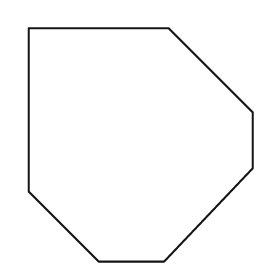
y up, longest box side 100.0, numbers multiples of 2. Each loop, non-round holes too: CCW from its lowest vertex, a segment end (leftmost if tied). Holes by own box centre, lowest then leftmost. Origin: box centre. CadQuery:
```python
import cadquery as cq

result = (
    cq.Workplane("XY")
    .moveTo(-18.0, -50.0)
    .lineTo(10.0, -50.0)
    .lineTo(48.0, -10.0)
    .lineTo(48.0, 14.0)
    .lineTo(12.0, 50.0)
    .lineTo(-48.0, 50.0)
    .lineTo(-48.0, -20.0)
    .close()
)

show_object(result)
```